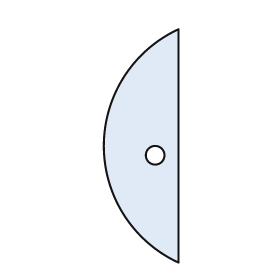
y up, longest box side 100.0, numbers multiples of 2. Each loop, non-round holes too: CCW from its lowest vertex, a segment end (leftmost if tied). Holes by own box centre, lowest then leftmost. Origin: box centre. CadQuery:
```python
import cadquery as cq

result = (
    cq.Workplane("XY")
    .moveTo(16.0, -50.0)
    .lineTo(16.0, 50.0)
    .threePointArc((-16.0, 0.0), (16.0, -50.0))
    .close()
    .moveTo(6.0, -4.0)
    .circle(4.0)
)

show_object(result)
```